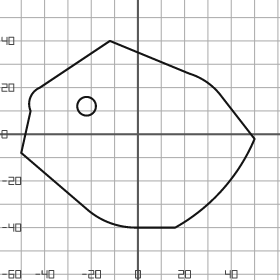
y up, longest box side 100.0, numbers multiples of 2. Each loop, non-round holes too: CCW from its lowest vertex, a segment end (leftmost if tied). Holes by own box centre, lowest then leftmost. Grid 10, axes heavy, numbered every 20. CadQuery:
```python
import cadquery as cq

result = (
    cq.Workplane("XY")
    .moveTo(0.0, -40.0)
    .lineTo(16.0, -40.0)
    .threePointArc((36.0, -24.0), (50.0, -2.0))
    .lineTo(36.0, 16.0)
    .threePointArc((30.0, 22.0), (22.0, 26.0))
    .lineTo(-12.0, 40.0)
    .lineTo(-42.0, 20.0)
    .threePointArc((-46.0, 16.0), (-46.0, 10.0))
    .lineTo(-50.0, -8.0)
    .lineTo(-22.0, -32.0)
    .threePointArc((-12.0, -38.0), (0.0, -40.0))
    .close()
    .moveTo(-22.0, 12.0)
    .circle(4.0)
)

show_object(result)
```